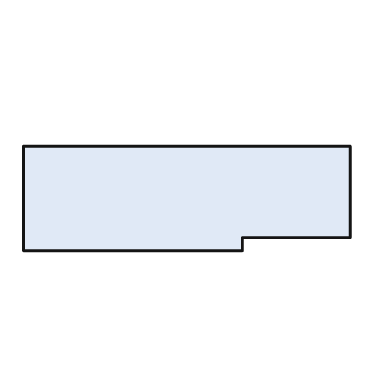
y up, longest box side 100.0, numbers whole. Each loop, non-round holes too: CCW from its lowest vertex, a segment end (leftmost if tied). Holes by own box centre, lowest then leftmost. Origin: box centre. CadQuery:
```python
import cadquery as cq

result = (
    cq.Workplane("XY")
    .moveTo(-50.0, -16.0)
    .lineTo(17.0, -16.0)
    .lineTo(17.0, -12.0)
    .lineTo(50.0, -12.0)
    .lineTo(50.0, 16.0)
    .lineTo(-50.0, 16.0)
    .close()
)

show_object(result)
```